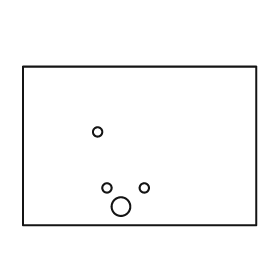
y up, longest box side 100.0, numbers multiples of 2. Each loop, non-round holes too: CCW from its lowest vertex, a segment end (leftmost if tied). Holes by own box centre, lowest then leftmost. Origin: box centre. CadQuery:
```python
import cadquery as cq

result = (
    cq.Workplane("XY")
    .moveTo(-50.0, -34.0)
    .lineTo(50.0, -34.0)
    .lineTo(50.0, 34.0)
    .lineTo(-50.0, 34.0)
    .close()
    .moveTo(-8.0, -26.0)
    .circle(4.0)
    .moveTo(-14.0, -18.0)
    .circle(2.0)
    .moveTo(2.0, -18.0)
    .circle(2.0)
    .moveTo(-18.0, 6.0)
    .circle(2.0)
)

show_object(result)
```